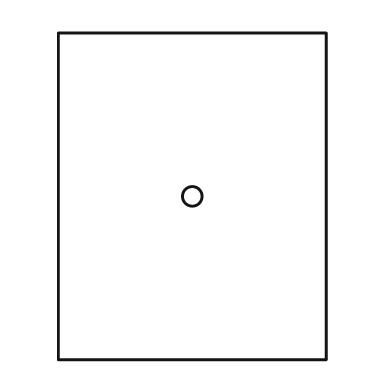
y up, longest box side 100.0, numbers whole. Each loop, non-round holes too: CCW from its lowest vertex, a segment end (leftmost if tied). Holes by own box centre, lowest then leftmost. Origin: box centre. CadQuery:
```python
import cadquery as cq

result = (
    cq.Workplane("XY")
    .moveTo(-41.0, -50.0)
    .lineTo(41.0, -50.0)
    .lineTo(41.0, 50.0)
    .lineTo(-41.0, 50.0)
    .close()
    .moveTo(0.0, 0.0)
    .circle(3.0)
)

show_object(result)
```